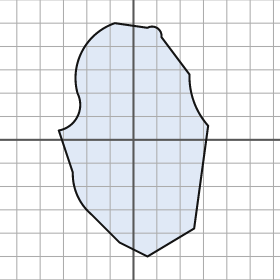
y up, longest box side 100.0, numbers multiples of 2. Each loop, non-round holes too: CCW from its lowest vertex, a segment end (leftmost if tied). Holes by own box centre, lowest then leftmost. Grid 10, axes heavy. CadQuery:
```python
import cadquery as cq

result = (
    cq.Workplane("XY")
    .moveTo(6.0, -50.0)
    .lineTo(26.0, -38.0)
    .lineTo(32.0, 6.0)
    .threePointArc((26.0, 16.0), (24.0, 28.0))
    .lineTo(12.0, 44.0)
    .threePointArc((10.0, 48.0), (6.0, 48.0))
    .lineTo(-8.0, 50.0)
    .threePointArc((-22.0, 38.0), (-24.0, 20.0))
    .threePointArc((-24.0, 10.0), (-32.0, 4.0))
    .lineTo(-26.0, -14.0)
    .threePointArc((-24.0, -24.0), (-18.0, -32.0))
    .lineTo(-6.0, -44.0)
    .close()
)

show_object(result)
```